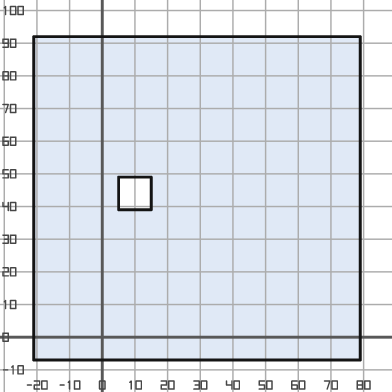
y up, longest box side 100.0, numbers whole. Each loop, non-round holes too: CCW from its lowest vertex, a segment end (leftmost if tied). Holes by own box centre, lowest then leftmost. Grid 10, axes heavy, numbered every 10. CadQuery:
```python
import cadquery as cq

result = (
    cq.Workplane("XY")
    .moveTo(-21.0, -7.0)
    .lineTo(79.0, -7.0)
    .lineTo(79.0, 92.0)
    .lineTo(-21.0, 92.0)
    .close()
    .moveTo(5.0, 39.0)
    .lineTo(15.0, 39.0)
    .lineTo(15.0, 49.0)
    .lineTo(5.0, 49.0)
    .close()
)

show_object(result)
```